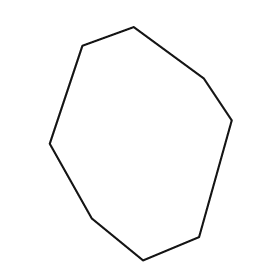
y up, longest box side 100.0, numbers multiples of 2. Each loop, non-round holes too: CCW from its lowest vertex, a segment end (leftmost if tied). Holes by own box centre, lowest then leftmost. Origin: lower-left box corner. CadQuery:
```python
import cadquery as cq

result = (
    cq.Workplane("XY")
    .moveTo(40.0, 0.0)
    .lineTo(64.0, 10.0)
    .lineTo(78.0, 60.0)
    .lineTo(66.0, 78.0)
    .lineTo(36.0, 100.0)
    .lineTo(14.0, 92.0)
    .lineTo(0.0, 50.0)
    .lineTo(18.0, 18.0)
    .close()
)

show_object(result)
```